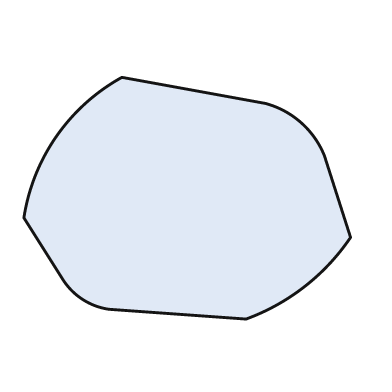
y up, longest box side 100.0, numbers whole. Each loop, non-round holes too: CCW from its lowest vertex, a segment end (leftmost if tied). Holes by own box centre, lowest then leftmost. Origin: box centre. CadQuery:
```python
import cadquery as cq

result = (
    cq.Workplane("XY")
    .moveTo(18.0, -37.0)
    .threePointArc((36.0, -27.0), (50.0, -12.0))
    .lineTo(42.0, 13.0)
    .threePointArc((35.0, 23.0), (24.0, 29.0))
    .lineTo(-20.0, 37.0)
    .threePointArc((-40.0, 19.0), (-50.0, -6.0))
    .lineTo(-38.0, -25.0)
    .threePointArc((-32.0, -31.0), (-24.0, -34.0))
    .close()
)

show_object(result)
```